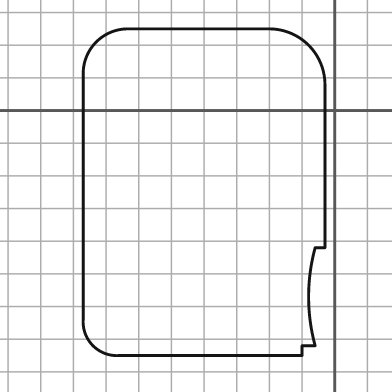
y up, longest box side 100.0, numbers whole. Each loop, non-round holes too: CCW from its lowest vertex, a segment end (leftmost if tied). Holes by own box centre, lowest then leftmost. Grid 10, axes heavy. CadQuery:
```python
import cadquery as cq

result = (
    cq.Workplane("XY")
    .moveTo(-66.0, -75.0)
    .lineTo(-10.0, -75.0)
    .lineTo(-10.0, -72.0)
    .lineTo(-6.0, -72.0)
    .threePointArc((-8.0, -57.0), (-6.0, -42.0))
    .lineTo(-3.0, -42.0)
    .lineTo(-3.0, 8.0)
    .threePointArc((-8.0, 20.0), (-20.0, 25.0))
    .lineTo(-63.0, 25.0)
    .threePointArc((-73.0, 21.0), (-77.0, 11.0))
    .lineTo(-77.0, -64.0)
    .threePointArc((-74.0, -72.0), (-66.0, -75.0))
    .close()
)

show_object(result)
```